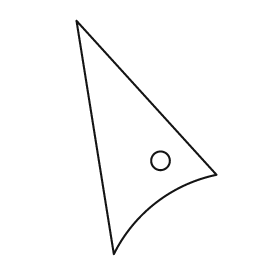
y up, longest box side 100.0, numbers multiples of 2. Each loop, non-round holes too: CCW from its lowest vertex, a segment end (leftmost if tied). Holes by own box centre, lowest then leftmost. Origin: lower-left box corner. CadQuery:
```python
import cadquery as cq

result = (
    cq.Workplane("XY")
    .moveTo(16.0, 0.0)
    .threePointArc((34.0, 22.0), (60.0, 34.0))
    .lineTo(0.0, 100.0)
    .close()
    .moveTo(36.0, 40.0)
    .circle(4.0)
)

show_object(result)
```